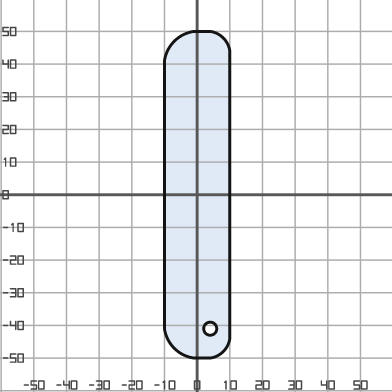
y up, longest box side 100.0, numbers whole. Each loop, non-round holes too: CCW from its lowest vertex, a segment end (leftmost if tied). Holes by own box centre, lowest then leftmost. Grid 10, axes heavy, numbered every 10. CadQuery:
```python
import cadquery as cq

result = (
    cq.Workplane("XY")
    .moveTo(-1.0, -50.0)
    .lineTo(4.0, -50.0)
    .threePointArc((8.0, -48.0), (10.0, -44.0))
    .lineTo(10.0, 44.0)
    .threePointArc((8.0, 48.0), (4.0, 50.0))
    .lineTo(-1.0, 50.0)
    .threePointArc((-7.0, 47.0), (-10.0, 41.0))
    .lineTo(-10.0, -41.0)
    .threePointArc((-7.0, -47.0), (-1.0, -50.0))
    .close()
    .moveTo(4.0, -41.0)
    .circle(2.0)
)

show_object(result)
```